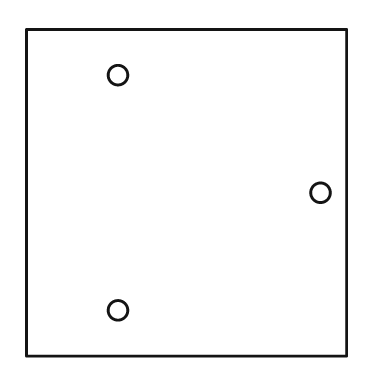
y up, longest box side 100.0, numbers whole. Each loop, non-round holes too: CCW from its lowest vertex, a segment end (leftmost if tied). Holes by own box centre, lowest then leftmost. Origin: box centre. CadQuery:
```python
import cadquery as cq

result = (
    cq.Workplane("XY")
    .moveTo(-49.0, -50.0)
    .lineTo(49.0, -50.0)
    .lineTo(49.0, 50.0)
    .lineTo(-49.0, 50.0)
    .close()
    .moveTo(-21.0, -36.0)
    .circle(3.0)
    .moveTo(41.0, 0.0)
    .circle(3.0)
    .moveTo(-21.0, 36.0)
    .circle(3.0)
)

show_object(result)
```